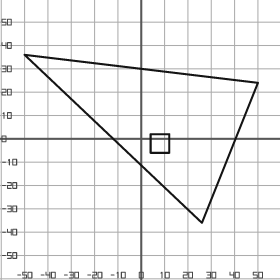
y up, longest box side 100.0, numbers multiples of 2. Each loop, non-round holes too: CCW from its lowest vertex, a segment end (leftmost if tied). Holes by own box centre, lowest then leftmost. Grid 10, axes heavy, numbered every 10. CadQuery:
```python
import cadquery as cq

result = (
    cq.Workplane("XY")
    .moveTo(26.0, -36.0)
    .lineTo(50.0, 24.0)
    .lineTo(-50.0, 36.0)
    .close()
    .moveTo(4.0, -6.0)
    .lineTo(12.0, -6.0)
    .lineTo(12.0, 2.0)
    .lineTo(4.0, 2.0)
    .close()
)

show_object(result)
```